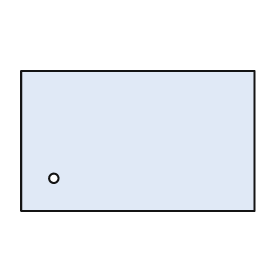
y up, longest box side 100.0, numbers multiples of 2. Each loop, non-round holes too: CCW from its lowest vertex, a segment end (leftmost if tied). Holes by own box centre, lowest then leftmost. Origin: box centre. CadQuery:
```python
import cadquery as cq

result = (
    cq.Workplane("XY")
    .moveTo(-50.0, -30.0)
    .lineTo(50.0, -30.0)
    .lineTo(50.0, 30.0)
    .lineTo(-50.0, 30.0)
    .close()
    .moveTo(-36.0, -16.0)
    .circle(2.0)
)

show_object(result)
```